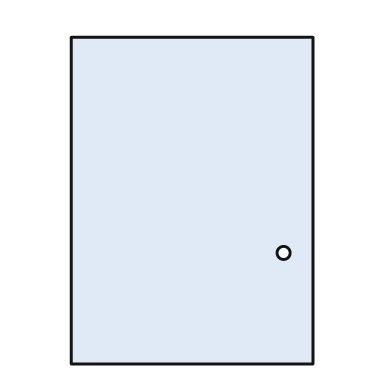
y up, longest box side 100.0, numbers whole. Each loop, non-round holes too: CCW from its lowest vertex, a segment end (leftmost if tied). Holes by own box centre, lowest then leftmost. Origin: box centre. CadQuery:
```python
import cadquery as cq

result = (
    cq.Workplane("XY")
    .moveTo(-37.0, -50.0)
    .lineTo(37.0, -50.0)
    .lineTo(37.0, 50.0)
    .lineTo(-37.0, 50.0)
    .close()
    .moveTo(28.0, -16.0)
    .circle(2.0)
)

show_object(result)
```